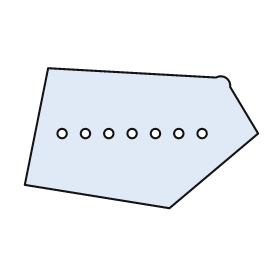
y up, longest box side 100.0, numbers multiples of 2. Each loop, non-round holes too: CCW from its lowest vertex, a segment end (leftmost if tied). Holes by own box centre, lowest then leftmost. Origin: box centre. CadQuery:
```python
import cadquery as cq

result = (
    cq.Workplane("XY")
    .moveTo(12.0, -30.0)
    .lineTo(50.0, 2.0)
    .lineTo(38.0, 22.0)
    .threePointArc((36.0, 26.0), (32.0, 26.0))
    .lineTo(-40.0, 30.0)
    .lineTo(-50.0, -20.0)
    .close()
    .moveTo(-34.0, 2.0)
    .circle(2.0)
    .moveTo(-24.0, 2.0)
    .circle(2.0)
    .moveTo(-14.0, 2.0)
    .circle(2.0)
    .moveTo(-4.0, 2.0)
    .circle(2.0)
    .moveTo(6.0, 2.0)
    .circle(2.0)
    .moveTo(16.0, 2.0)
    .circle(2.0)
    .moveTo(26.0, 2.0)
    .circle(2.0)
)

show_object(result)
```